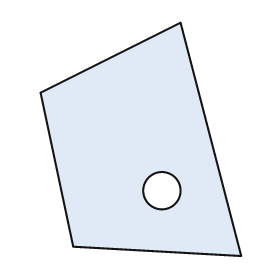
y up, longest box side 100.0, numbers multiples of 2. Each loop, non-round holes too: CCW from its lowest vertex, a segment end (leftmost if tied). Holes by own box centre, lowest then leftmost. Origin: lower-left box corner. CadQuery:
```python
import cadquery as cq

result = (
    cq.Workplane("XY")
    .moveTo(86.0, 0.0)
    .lineTo(60.0, 100.0)
    .lineTo(0.0, 70.0)
    .lineTo(14.0, 4.0)
    .close()
    .moveTo(52.0, 28.0)
    .circle(8.0)
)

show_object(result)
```